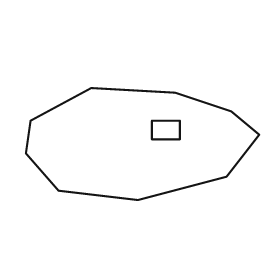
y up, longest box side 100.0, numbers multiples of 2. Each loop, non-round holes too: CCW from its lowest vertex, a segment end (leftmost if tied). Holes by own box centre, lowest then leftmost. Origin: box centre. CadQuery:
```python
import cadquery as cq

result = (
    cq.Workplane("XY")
    .moveTo(-2.0, -24.0)
    .lineTo(36.0, -14.0)
    .lineTo(50.0, 4.0)
    .lineTo(38.0, 14.0)
    .lineTo(14.0, 22.0)
    .lineTo(-22.0, 24.0)
    .lineTo(-48.0, 10.0)
    .lineTo(-50.0, -4.0)
    .lineTo(-36.0, -20.0)
    .close()
    .moveTo(4.0, 2.0)
    .lineTo(16.0, 2.0)
    .lineTo(16.0, 10.0)
    .lineTo(4.0, 10.0)
    .close()
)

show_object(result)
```